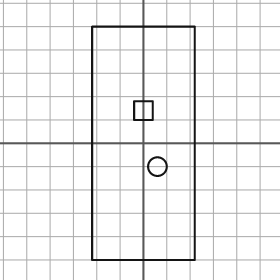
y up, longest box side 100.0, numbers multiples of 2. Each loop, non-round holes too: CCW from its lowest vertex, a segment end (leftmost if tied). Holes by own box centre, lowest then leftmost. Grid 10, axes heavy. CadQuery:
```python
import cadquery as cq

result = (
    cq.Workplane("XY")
    .moveTo(-22.0, -50.0)
    .lineTo(22.0, -50.0)
    .lineTo(22.0, 50.0)
    .lineTo(-22.0, 50.0)
    .close()
    .moveTo(6.0, -10.0)
    .circle(4.0)
    .moveTo(-4.0, 10.0)
    .lineTo(4.0, 10.0)
    .lineTo(4.0, 18.0)
    .lineTo(-4.0, 18.0)
    .close()
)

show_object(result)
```